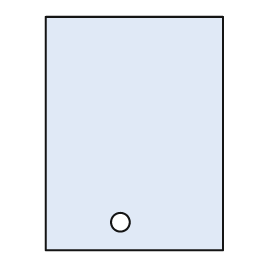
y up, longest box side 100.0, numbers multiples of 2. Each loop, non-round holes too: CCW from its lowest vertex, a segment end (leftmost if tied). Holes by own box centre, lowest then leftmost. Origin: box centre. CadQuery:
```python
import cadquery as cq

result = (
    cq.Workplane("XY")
    .moveTo(-38.0, -50.0)
    .lineTo(38.0, -50.0)
    .lineTo(38.0, 50.0)
    .lineTo(-38.0, 50.0)
    .close()
    .moveTo(-6.0, -38.0)
    .circle(4.0)
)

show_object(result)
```